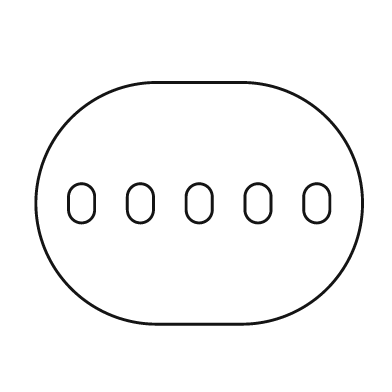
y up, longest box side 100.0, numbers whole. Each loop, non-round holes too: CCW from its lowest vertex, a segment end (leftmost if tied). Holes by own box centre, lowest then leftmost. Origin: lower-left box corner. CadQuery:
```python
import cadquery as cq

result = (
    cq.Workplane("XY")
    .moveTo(37.0, 0.0)
    .lineTo(63.0, 0.0)
    .threePointArc((100.0, 37.0), (63.0, 74.0))
    .lineTo(37.0, 74.0)
    .threePointArc((0.0, 37.0), (37.0, 0.0))
    .close()
    .moveTo(10.0, 35.0)
    .threePointArc((14.0, 31.0), (18.0, 35.0))
    .lineTo(18.0, 39.0)
    .threePointArc((14.0, 43.0), (10.0, 39.0))
    .close()
    .moveTo(28.0, 35.0)
    .threePointArc((32.0, 31.0), (36.0, 35.0))
    .lineTo(36.0, 39.0)
    .threePointArc((32.0, 43.0), (28.0, 39.0))
    .close()
    .moveTo(46.0, 35.0)
    .threePointArc((50.0, 31.0), (54.0, 35.0))
    .lineTo(54.0, 39.0)
    .threePointArc((50.0, 43.0), (46.0, 39.0))
    .close()
    .moveTo(64.0, 35.0)
    .threePointArc((68.0, 31.0), (72.0, 35.0))
    .lineTo(72.0, 39.0)
    .threePointArc((68.0, 43.0), (64.0, 39.0))
    .close()
    .moveTo(82.0, 35.0)
    .threePointArc((86.0, 31.0), (90.0, 35.0))
    .lineTo(90.0, 39.0)
    .threePointArc((86.0, 43.0), (82.0, 39.0))
    .close()
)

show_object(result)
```